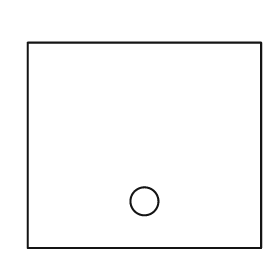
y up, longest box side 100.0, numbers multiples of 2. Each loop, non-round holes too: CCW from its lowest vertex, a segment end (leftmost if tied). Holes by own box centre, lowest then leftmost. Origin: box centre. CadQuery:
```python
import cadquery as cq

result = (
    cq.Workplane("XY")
    .moveTo(-50.0, -44.0)
    .lineTo(50.0, -44.0)
    .lineTo(50.0, 44.0)
    .lineTo(-50.0, 44.0)
    .close()
    .moveTo(0.0, -24.0)
    .circle(6.0)
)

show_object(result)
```